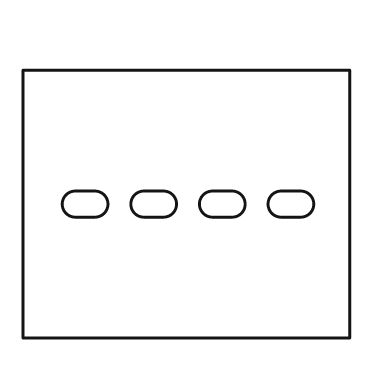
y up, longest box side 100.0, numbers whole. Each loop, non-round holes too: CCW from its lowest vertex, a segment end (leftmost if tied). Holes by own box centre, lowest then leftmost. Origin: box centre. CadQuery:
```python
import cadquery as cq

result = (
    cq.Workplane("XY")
    .moveTo(-50.0, -41.0)
    .lineTo(50.0, -41.0)
    .lineTo(50.0, 41.0)
    .lineTo(-50.0, 41.0)
    .close()
    .moveTo(-34.0, -4.0)
    .lineTo(-28.0, -4.0)
    .threePointArc((-24.0, 0.0), (-28.0, 4.0))
    .lineTo(-34.0, 4.0)
    .threePointArc((-38.0, 0.0), (-34.0, -4.0))
    .close()
    .moveTo(-13.0, -4.0)
    .lineTo(-7.0, -4.0)
    .threePointArc((-3.0, 0.0), (-7.0, 4.0))
    .lineTo(-13.0, 4.0)
    .threePointArc((-17.0, 0.0), (-13.0, -4.0))
    .close()
    .moveTo(8.0, -4.0)
    .lineTo(14.0, -4.0)
    .threePointArc((18.0, 0.0), (14.0, 4.0))
    .lineTo(8.0, 4.0)
    .threePointArc((4.0, 0.0), (8.0, -4.0))
    .close()
    .moveTo(29.0, -4.0)
    .lineTo(35.0, -4.0)
    .threePointArc((39.0, 0.0), (35.0, 4.0))
    .lineTo(29.0, 4.0)
    .threePointArc((25.0, 0.0), (29.0, -4.0))
    .close()
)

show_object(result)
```